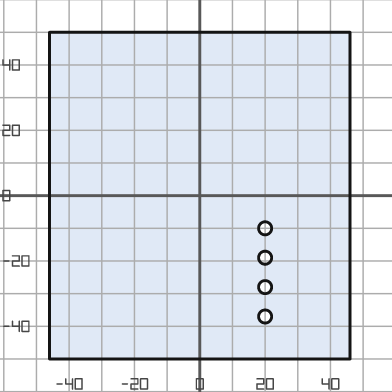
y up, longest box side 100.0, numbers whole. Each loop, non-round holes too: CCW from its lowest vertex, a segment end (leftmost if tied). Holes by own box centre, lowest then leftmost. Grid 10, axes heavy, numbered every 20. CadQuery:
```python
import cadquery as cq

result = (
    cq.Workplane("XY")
    .moveTo(-46.0, -50.0)
    .lineTo(46.0, -50.0)
    .lineTo(46.0, 50.0)
    .lineTo(-46.0, 50.0)
    .close()
    .moveTo(20.0, -37.0)
    .circle(2.0)
    .moveTo(20.0, -28.0)
    .circle(2.0)
    .moveTo(20.0, -19.0)
    .circle(2.0)
    .moveTo(20.0, -10.0)
    .circle(2.0)
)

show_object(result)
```